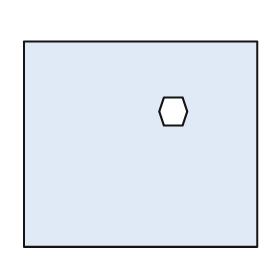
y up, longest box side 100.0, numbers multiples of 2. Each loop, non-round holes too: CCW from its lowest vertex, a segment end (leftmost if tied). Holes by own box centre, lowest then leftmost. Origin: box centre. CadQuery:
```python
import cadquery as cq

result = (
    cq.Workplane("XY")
    .moveTo(-50.0, -44.0)
    .lineTo(50.0, -44.0)
    .lineTo(50.0, 44.0)
    .lineTo(-50.0, 44.0)
    .close()
    .moveTo(10.0, 8.0)
    .lineTo(18.0, 8.0)
    .lineTo(20.0, 14.0)
    .lineTo(18.0, 20.0)
    .lineTo(10.0, 20.0)
    .lineTo(8.0, 14.0)
    .close()
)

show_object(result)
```